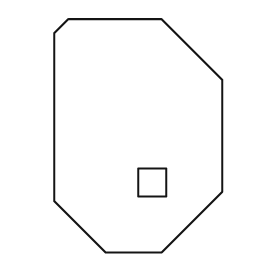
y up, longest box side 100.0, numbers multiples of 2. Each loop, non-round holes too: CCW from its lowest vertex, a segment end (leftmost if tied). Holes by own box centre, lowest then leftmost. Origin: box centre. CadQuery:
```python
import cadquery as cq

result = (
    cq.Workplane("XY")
    .moveTo(-14.0, -50.0)
    .lineTo(10.0, -50.0)
    .lineTo(36.0, -24.0)
    .lineTo(36.0, 24.0)
    .lineTo(10.0, 50.0)
    .lineTo(-30.0, 50.0)
    .lineTo(-36.0, 44.0)
    .lineTo(-36.0, -28.0)
    .close()
    .moveTo(0.0, -26.0)
    .lineTo(12.0, -26.0)
    .lineTo(12.0, -14.0)
    .lineTo(0.0, -14.0)
    .close()
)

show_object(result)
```